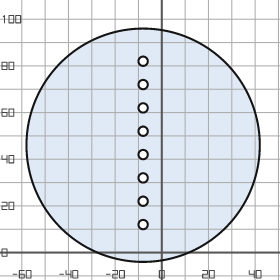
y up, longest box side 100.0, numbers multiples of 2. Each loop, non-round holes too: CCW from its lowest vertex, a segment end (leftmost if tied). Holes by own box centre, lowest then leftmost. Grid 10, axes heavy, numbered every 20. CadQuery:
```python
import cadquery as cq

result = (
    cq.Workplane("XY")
    .moveTo(-8.0, 46.0)
    .circle(50.0)
    .moveTo(-8.0, 12.0)
    .circle(2.0)
    .moveTo(-8.0, 22.0)
    .circle(2.0)
    .moveTo(-8.0, 32.0)
    .circle(2.0)
    .moveTo(-8.0, 42.0)
    .circle(2.0)
    .moveTo(-8.0, 52.0)
    .circle(2.0)
    .moveTo(-8.0, 62.0)
    .circle(2.0)
    .moveTo(-8.0, 72.0)
    .circle(2.0)
    .moveTo(-8.0, 82.0)
    .circle(2.0)
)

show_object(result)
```